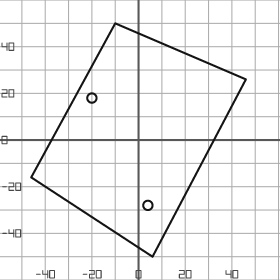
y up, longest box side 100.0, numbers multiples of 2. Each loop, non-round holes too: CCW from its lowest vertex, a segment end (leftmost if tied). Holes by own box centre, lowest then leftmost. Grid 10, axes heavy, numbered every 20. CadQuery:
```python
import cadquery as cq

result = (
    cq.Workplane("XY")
    .moveTo(6.0, -50.0)
    .lineTo(46.0, 26.0)
    .lineTo(-10.0, 50.0)
    .lineTo(-46.0, -16.0)
    .close()
    .moveTo(4.0, -28.0)
    .circle(2.0)
    .moveTo(-20.0, 18.0)
    .circle(2.0)
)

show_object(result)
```